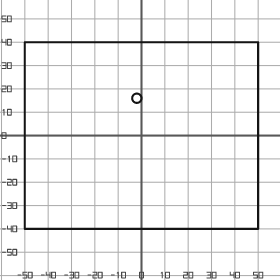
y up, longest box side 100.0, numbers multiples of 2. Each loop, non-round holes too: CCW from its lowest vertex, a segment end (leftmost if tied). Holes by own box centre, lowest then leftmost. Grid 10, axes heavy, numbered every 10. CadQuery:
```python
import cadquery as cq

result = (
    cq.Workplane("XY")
    .moveTo(-50.0, -40.0)
    .lineTo(50.0, -40.0)
    .lineTo(50.0, 40.0)
    .lineTo(-50.0, 40.0)
    .close()
    .moveTo(-2.0, 16.0)
    .circle(2.0)
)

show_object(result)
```